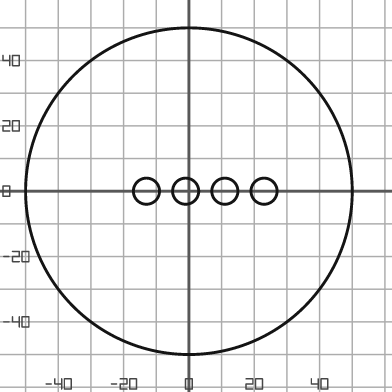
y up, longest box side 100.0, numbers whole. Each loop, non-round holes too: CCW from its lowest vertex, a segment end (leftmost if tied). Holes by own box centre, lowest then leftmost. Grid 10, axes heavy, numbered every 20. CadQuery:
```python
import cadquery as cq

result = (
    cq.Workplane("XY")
    .moveTo(0.0, 0.0)
    .circle(50.0)
    .moveTo(-13.0, 0.0)
    .circle(4.0)
    .moveTo(-1.0, 0.0)
    .circle(4.0)
    .moveTo(11.0, 0.0)
    .circle(4.0)
    .moveTo(23.0, 0.0)
    .circle(4.0)
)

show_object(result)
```